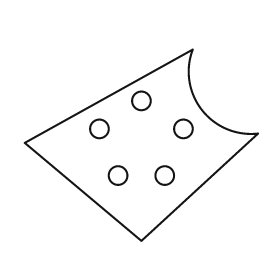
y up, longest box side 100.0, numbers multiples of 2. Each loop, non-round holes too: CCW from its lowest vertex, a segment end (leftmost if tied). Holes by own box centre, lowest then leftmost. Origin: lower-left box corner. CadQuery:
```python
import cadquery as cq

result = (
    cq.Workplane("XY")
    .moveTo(50.0, 0.0)
    .lineTo(100.0, 46.0)
    .threePointArc((76.0, 56.0), (72.0, 82.0))
    .lineTo(0.0, 42.0)
    .close()
    .moveTo(40.0, 28.0)
    .circle(4.0)
    .moveTo(60.0, 28.0)
    .circle(4.0)
    .moveTo(32.0, 48.0)
    .circle(4.0)
    .moveTo(68.0, 48.0)
    .circle(4.0)
    .moveTo(50.0, 60.0)
    .circle(4.0)
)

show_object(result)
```